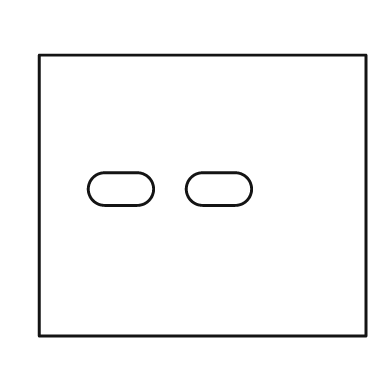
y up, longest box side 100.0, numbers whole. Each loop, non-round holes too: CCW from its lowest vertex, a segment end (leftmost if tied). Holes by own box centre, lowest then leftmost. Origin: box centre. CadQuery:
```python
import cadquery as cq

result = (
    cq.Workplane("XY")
    .moveTo(-50.0, -43.0)
    .lineTo(50.0, -43.0)
    .lineTo(50.0, 43.0)
    .lineTo(-50.0, 43.0)
    .close()
    .moveTo(-30.0, -3.0)
    .lineTo(-20.0, -3.0)
    .threePointArc((-15.0, 2.0), (-20.0, 7.0))
    .lineTo(-30.0, 7.0)
    .threePointArc((-35.0, 2.0), (-30.0, -3.0))
    .close()
    .moveTo(0.0, -3.0)
    .lineTo(10.0, -3.0)
    .threePointArc((15.0, 2.0), (10.0, 7.0))
    .lineTo(0.0, 7.0)
    .threePointArc((-5.0, 2.0), (0.0, -3.0))
    .close()
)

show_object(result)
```